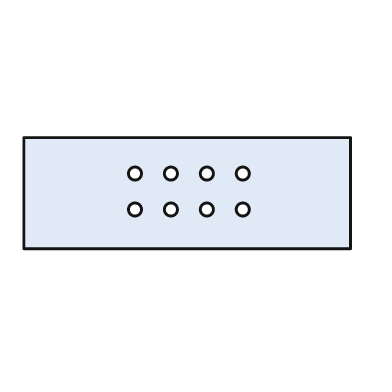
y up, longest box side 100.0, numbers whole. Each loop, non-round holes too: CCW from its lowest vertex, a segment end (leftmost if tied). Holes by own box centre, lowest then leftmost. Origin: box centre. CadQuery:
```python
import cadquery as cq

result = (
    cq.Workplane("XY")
    .moveTo(-50.0, -17.0)
    .lineTo(50.0, -17.0)
    .lineTo(50.0, 17.0)
    .lineTo(-50.0, 17.0)
    .close()
    .moveTo(-16.0, -5.0)
    .circle(2.0)
    .moveTo(-5.0, -5.0)
    .circle(2.0)
    .moveTo(6.0, -5.0)
    .circle(2.0)
    .moveTo(17.0, -5.0)
    .circle(2.0)
    .moveTo(-16.0, 6.0)
    .circle(2.0)
    .moveTo(-5.0, 6.0)
    .circle(2.0)
    .moveTo(6.0, 6.0)
    .circle(2.0)
    .moveTo(17.0, 6.0)
    .circle(2.0)
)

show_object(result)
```